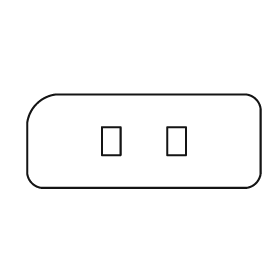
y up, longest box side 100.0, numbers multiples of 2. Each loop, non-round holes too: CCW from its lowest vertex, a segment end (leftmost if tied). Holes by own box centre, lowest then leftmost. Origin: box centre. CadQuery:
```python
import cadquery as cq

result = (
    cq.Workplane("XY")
    .moveTo(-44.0, -20.0)
    .lineTo(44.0, -20.0)
    .threePointArc((48.0, -18.0), (50.0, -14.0))
    .lineTo(50.0, 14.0)
    .threePointArc((48.0, 18.0), (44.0, 20.0))
    .lineTo(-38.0, 20.0)
    .threePointArc((-46.0, 16.0), (-50.0, 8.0))
    .lineTo(-50.0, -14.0)
    .threePointArc((-48.0, -18.0), (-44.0, -20.0))
    .close()
    .moveTo(-18.0, -6.0)
    .lineTo(-10.0, -6.0)
    .lineTo(-10.0, 6.0)
    .lineTo(-18.0, 6.0)
    .close()
    .moveTo(10.0, -6.0)
    .lineTo(18.0, -6.0)
    .lineTo(18.0, 6.0)
    .lineTo(10.0, 6.0)
    .close()
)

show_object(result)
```